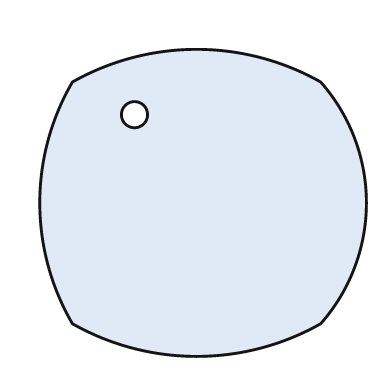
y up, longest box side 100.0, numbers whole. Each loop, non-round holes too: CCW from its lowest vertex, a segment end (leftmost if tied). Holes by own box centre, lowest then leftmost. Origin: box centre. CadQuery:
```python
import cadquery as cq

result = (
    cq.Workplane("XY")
    .moveTo(-40.0, -37.0)
    .threePointArc((-2.0, -47.0), (36.0, -37.0))
    .threePointArc((50.0, 0.0), (36.0, 37.0))
    .threePointArc((-2.0, 47.0), (-40.0, 37.0))
    .threePointArc((-50.0, 0.0), (-40.0, -37.0))
    .close()
    .moveTo(-21.0, 27.0)
    .circle(4.0)
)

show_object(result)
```